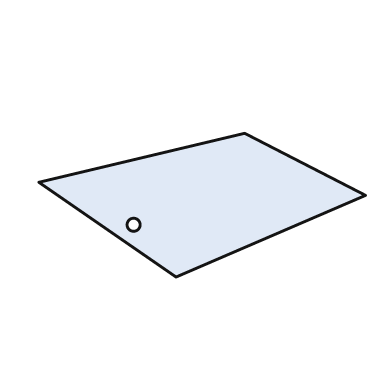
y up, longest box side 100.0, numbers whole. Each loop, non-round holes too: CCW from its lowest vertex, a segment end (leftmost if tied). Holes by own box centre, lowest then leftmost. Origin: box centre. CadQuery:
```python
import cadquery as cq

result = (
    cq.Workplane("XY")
    .moveTo(-8.0, -22.0)
    .lineTo(50.0, 3.0)
    .lineTo(13.0, 22.0)
    .lineTo(-50.0, 7.0)
    .close()
    .moveTo(-21.0, -6.0)
    .circle(2.0)
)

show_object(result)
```